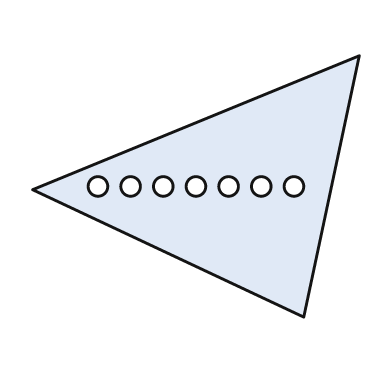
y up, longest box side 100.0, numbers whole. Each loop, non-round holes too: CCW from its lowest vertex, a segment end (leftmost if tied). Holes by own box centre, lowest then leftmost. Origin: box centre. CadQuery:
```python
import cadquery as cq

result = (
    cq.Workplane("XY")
    .moveTo(33.0, -40.0)
    .lineTo(50.0, 40.0)
    .lineTo(-50.0, -1.0)
    .close()
    .moveTo(-30.0, 0.0)
    .circle(3.0)
    .moveTo(-20.0, 0.0)
    .circle(3.0)
    .moveTo(-10.0, 0.0)
    .circle(3.0)
    .moveTo(0.0, 0.0)
    .circle(3.0)
    .moveTo(10.0, 0.0)
    .circle(3.0)
    .moveTo(20.0, 0.0)
    .circle(3.0)
    .moveTo(30.0, 0.0)
    .circle(3.0)
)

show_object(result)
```